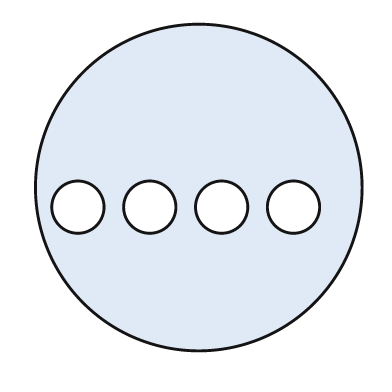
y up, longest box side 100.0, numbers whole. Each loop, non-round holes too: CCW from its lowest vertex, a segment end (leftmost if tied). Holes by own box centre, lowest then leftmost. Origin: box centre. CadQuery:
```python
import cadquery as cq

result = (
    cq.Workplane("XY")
    .moveTo(0.0, 0.0)
    .circle(50.0)
    .moveTo(-37.0, -6.0)
    .circle(8.0)
    .moveTo(-15.0, -6.0)
    .circle(8.0)
    .moveTo(7.0, -6.0)
    .circle(8.0)
    .moveTo(29.0, -6.0)
    .circle(8.0)
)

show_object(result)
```